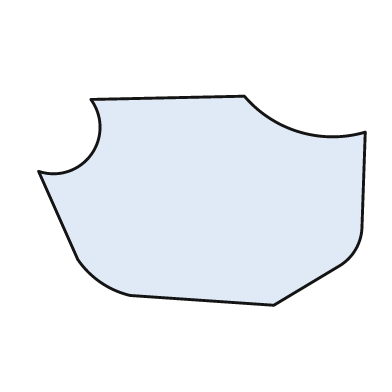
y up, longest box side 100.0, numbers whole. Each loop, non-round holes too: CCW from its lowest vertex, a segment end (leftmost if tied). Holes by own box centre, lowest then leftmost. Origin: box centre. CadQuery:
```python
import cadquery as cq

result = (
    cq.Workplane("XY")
    .moveTo(22.0, -32.0)
    .lineTo(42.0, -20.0)
    .threePointArc((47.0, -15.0), (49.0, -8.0))
    .lineTo(50.0, 21.0)
    .threePointArc((30.0, 21.0), (13.0, 32.0))
    .lineTo(-34.0, 31.0)
    .threePointArc((-34.0, 14.0), (-50.0, 9.0))
    .lineTo(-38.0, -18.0)
    .threePointArc((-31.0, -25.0), (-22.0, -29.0))
    .close()
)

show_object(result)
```